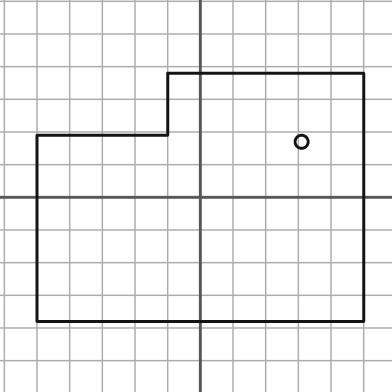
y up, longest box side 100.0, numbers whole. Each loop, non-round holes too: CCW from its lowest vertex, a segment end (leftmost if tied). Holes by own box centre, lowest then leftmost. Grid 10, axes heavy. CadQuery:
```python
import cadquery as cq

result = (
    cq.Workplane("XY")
    .moveTo(-50.0, -38.0)
    .lineTo(50.0, -38.0)
    .lineTo(50.0, 38.0)
    .lineTo(-10.0, 38.0)
    .lineTo(-10.0, 19.0)
    .lineTo(-50.0, 19.0)
    .close()
    .moveTo(31.0, 17.0)
    .circle(2.0)
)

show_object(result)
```